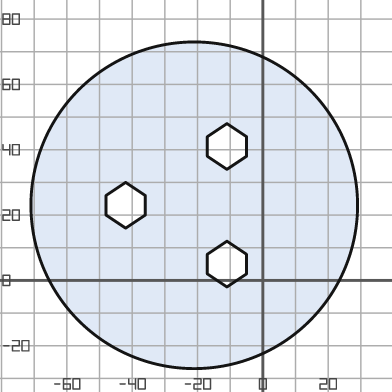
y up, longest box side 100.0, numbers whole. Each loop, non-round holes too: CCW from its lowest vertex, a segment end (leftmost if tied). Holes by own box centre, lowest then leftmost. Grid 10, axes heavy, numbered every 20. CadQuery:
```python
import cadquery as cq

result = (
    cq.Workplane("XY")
    .moveTo(-21.0, 23.0)
    .circle(50.0)
    .moveTo(-11.0, -2.0)
    .lineTo(-5.0, 2.0)
    .lineTo(-5.0, 8.0)
    .lineTo(-11.0, 12.0)
    .lineTo(-17.0, 8.0)
    .lineTo(-17.0, 2.0)
    .close()
    .moveTo(-42.0, 16.0)
    .lineTo(-36.0, 20.0)
    .lineTo(-36.0, 26.0)
    .lineTo(-42.0, 30.0)
    .lineTo(-48.0, 26.0)
    .lineTo(-48.0, 20.0)
    .close()
    .moveTo(-11.0, 34.0)
    .lineTo(-5.0, 38.0)
    .lineTo(-5.0, 44.0)
    .lineTo(-11.0, 48.0)
    .lineTo(-17.0, 44.0)
    .lineTo(-17.0, 38.0)
    .close()
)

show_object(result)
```